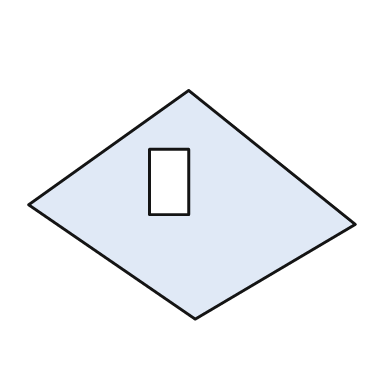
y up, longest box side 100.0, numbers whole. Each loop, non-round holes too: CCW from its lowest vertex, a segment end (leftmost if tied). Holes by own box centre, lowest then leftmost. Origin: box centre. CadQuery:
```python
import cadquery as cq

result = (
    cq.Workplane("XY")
    .moveTo(1.0, -35.0)
    .lineTo(50.0, -6.0)
    .lineTo(-1.0, 35.0)
    .lineTo(-50.0, 0.0)
    .close()
    .moveTo(-13.0, -3.0)
    .lineTo(-1.0, -3.0)
    .lineTo(-1.0, 17.0)
    .lineTo(-13.0, 17.0)
    .close()
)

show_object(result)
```